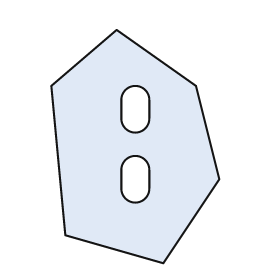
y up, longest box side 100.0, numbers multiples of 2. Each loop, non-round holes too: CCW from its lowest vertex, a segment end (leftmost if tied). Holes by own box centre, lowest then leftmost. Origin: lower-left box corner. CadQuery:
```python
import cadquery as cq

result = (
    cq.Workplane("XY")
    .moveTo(48.0, 0.0)
    .lineTo(72.0, 36.0)
    .lineTo(62.0, 76.0)
    .lineTo(28.0, 100.0)
    .lineTo(0.0, 76.0)
    .lineTo(6.0, 12.0)
    .close()
    .moveTo(30.0, 32.0)
    .threePointArc((36.0, 26.0), (42.0, 32.0))
    .lineTo(42.0, 40.0)
    .threePointArc((36.0, 46.0), (30.0, 40.0))
    .close()
    .moveTo(30.0, 62.0)
    .threePointArc((36.0, 56.0), (42.0, 62.0))
    .lineTo(42.0, 70.0)
    .threePointArc((36.0, 76.0), (30.0, 70.0))
    .close()
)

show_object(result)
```